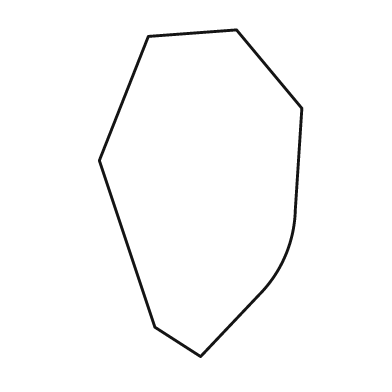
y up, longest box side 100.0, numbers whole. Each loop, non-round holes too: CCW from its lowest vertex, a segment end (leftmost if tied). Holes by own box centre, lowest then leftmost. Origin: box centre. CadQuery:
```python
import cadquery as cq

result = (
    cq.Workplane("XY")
    .moveTo(0.0, -50.0)
    .lineTo(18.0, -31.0)
    .threePointArc((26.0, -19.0), (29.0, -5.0))
    .lineTo(31.0, 26.0)
    .lineTo(11.0, 50.0)
    .lineTo(-16.0, 48.0)
    .lineTo(-31.0, 10.0)
    .lineTo(-14.0, -41.0)
    .close()
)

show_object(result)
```